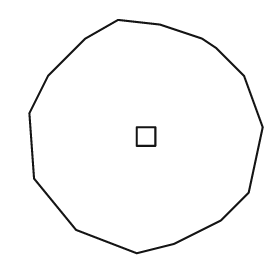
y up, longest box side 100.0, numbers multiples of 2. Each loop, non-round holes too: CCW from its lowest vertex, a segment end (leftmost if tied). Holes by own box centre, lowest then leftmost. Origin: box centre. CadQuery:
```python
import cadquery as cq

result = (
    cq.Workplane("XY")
    .moveTo(-4.0, -50.0)
    .lineTo(12.0, -46.0)
    .lineTo(32.0, -36.0)
    .lineTo(44.0, -24.0)
    .lineTo(50.0, 4.0)
    .lineTo(42.0, 26.0)
    .lineTo(30.0, 38.0)
    .lineTo(24.0, 42.0)
    .lineTo(6.0, 48.0)
    .lineTo(-12.0, 50.0)
    .lineTo(-26.0, 42.0)
    .lineTo(-42.0, 26.0)
    .lineTo(-50.0, 10.0)
    .lineTo(-48.0, -18.0)
    .lineTo(-30.0, -40.0)
    .close()
    .moveTo(-4.0, -4.0)
    .lineTo(4.0, -4.0)
    .lineTo(4.0, 4.0)
    .lineTo(-4.0, 4.0)
    .close()
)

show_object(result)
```